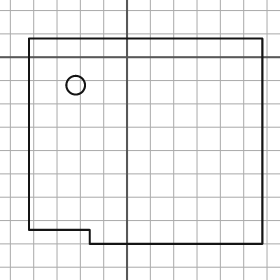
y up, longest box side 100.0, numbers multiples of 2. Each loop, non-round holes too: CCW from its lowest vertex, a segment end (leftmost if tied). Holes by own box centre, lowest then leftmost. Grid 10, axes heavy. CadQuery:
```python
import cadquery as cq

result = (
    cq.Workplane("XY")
    .moveTo(-16.0, -80.0)
    .lineTo(58.0, -80.0)
    .lineTo(58.0, 8.0)
    .lineTo(-42.0, 8.0)
    .lineTo(-42.0, -74.0)
    .lineTo(-16.0, -74.0)
    .close()
    .moveTo(-22.0, -12.0)
    .circle(4.0)
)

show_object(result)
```